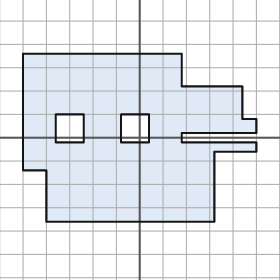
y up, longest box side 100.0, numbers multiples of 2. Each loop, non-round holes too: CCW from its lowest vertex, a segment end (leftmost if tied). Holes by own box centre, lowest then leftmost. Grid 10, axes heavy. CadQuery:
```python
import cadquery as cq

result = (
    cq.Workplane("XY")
    .moveTo(-40.0, -36.0)
    .lineTo(32.0, -36.0)
    .lineTo(32.0, -6.0)
    .lineTo(50.0, -6.0)
    .lineTo(50.0, -2.0)
    .lineTo(18.0, -2.0)
    .lineTo(18.0, 2.0)
    .lineTo(50.0, 2.0)
    .lineTo(50.0, 8.0)
    .lineTo(44.0, 8.0)
    .lineTo(44.0, 22.0)
    .lineTo(18.0, 22.0)
    .lineTo(18.0, 36.0)
    .lineTo(-50.0, 36.0)
    .lineTo(-50.0, -14.0)
    .lineTo(-40.0, -14.0)
    .close()
    .moveTo(-36.0, -2.0)
    .lineTo(-24.0, -2.0)
    .lineTo(-24.0, 10.0)
    .lineTo(-36.0, 10.0)
    .close()
    .moveTo(-8.0, -2.0)
    .lineTo(4.0, -2.0)
    .lineTo(4.0, 10.0)
    .lineTo(-8.0, 10.0)
    .close()
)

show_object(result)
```